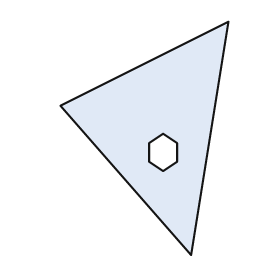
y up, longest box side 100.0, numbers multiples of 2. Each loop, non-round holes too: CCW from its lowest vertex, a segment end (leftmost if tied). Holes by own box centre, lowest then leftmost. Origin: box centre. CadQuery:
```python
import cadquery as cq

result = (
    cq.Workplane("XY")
    .moveTo(20.0, -50.0)
    .lineTo(36.0, 50.0)
    .lineTo(-36.0, 14.0)
    .close()
    .moveTo(8.0, -14.0)
    .lineTo(14.0, -10.0)
    .lineTo(14.0, -2.0)
    .lineTo(8.0, 2.0)
    .lineTo(2.0, -2.0)
    .lineTo(2.0, -10.0)
    .close()
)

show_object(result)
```